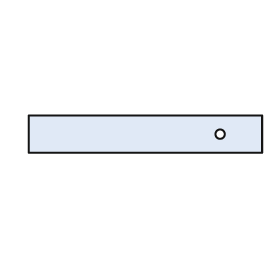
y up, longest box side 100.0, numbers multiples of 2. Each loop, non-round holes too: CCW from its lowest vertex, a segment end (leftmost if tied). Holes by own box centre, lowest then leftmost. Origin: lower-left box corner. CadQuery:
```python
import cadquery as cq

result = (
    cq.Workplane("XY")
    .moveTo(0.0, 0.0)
    .lineTo(100.0, 0.0)
    .lineTo(100.0, 16.0)
    .lineTo(0.0, 16.0)
    .close()
    .moveTo(82.0, 8.0)
    .circle(2.0)
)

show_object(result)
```